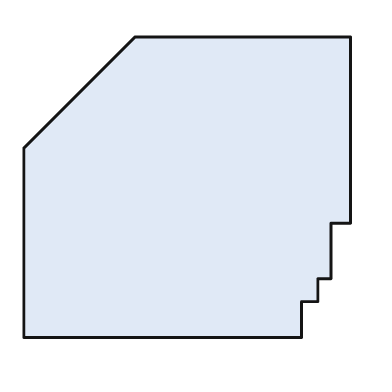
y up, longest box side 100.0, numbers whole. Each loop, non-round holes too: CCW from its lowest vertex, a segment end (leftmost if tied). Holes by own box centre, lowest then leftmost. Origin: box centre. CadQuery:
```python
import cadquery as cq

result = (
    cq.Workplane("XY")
    .moveTo(-50.0, -46.0)
    .lineTo(35.0, -46.0)
    .lineTo(35.0, -35.0)
    .lineTo(40.0, -35.0)
    .lineTo(40.0, -28.0)
    .lineTo(44.0, -28.0)
    .lineTo(44.0, -11.0)
    .lineTo(50.0, -11.0)
    .lineTo(50.0, 46.0)
    .lineTo(-16.0, 46.0)
    .lineTo(-50.0, 12.0)
    .close()
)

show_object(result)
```